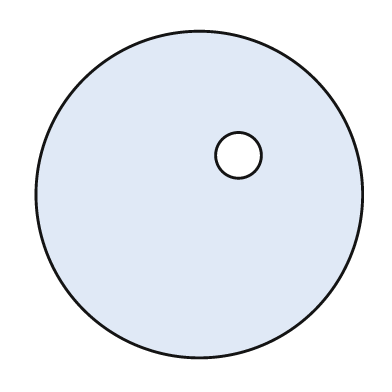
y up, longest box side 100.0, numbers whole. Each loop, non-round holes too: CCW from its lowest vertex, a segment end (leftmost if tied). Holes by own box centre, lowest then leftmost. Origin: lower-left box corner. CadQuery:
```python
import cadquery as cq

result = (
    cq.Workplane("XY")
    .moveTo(50.0, 50.0)
    .circle(50.0)
    .moveTo(62.0, 62.0)
    .circle(7.0)
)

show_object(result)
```